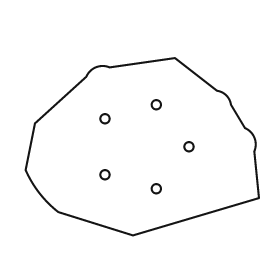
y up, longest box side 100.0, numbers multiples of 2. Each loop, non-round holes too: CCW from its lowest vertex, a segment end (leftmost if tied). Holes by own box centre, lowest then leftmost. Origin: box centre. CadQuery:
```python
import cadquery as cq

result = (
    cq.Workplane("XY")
    .moveTo(-4.0, -38.0)
    .lineTo(50.0, -22.0)
    .lineTo(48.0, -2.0)
    .threePointArc((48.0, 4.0), (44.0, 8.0))
    .lineTo(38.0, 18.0)
    .threePointArc((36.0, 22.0), (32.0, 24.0))
    .lineTo(14.0, 38.0)
    .lineTo(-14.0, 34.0)
    .threePointArc((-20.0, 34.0), (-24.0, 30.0))
    .lineTo(-46.0, 10.0)
    .lineTo(-50.0, -10.0)
    .threePointArc((-44.0, -20.0), (-36.0, -28.0))
    .close()
    .moveTo(6.0, -18.0)
    .circle(2.0)
    .moveTo(-16.0, -12.0)
    .circle(2.0)
    .moveTo(20.0, 0.0)
    .circle(2.0)
    .moveTo(-16.0, 12.0)
    .circle(2.0)
    .moveTo(6.0, 18.0)
    .circle(2.0)
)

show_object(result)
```